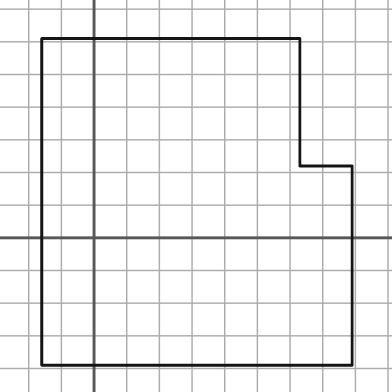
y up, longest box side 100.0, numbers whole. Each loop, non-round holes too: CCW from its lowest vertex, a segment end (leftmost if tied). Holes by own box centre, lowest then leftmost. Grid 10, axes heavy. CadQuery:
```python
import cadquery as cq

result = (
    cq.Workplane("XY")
    .moveTo(-16.0, -39.0)
    .lineTo(79.0, -39.0)
    .lineTo(79.0, 22.0)
    .lineTo(63.0, 22.0)
    .lineTo(63.0, 61.0)
    .lineTo(-16.0, 61.0)
    .close()
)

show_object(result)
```